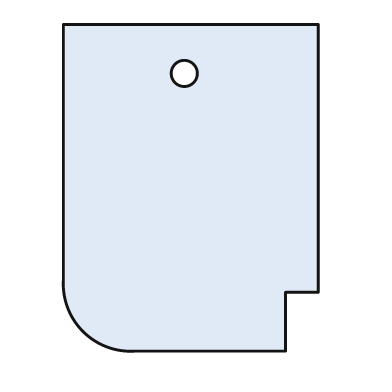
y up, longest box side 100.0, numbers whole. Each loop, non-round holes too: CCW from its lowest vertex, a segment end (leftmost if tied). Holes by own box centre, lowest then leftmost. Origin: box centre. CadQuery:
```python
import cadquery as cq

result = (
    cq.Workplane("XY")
    .moveTo(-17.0, -50.0)
    .lineTo(29.0, -50.0)
    .lineTo(29.0, -32.0)
    .lineTo(39.0, -32.0)
    .lineTo(39.0, 50.0)
    .lineTo(-39.0, 50.0)
    .lineTo(-39.0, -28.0)
    .threePointArc((-33.0, -44.0), (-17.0, -50.0))
    .close()
    .moveTo(-2.0, 35.0)
    .circle(4.0)
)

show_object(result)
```